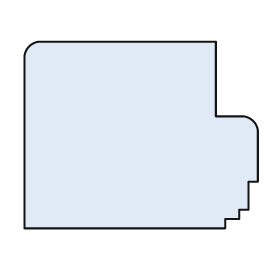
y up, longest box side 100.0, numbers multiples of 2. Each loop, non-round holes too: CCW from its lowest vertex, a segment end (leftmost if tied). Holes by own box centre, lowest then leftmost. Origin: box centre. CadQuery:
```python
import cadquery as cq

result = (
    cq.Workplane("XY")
    .moveTo(-50.0, -40.0)
    .lineTo(36.0, -40.0)
    .lineTo(36.0, -36.0)
    .lineTo(42.0, -36.0)
    .lineTo(42.0, -32.0)
    .lineTo(46.0, -32.0)
    .lineTo(46.0, -20.0)
    .lineTo(50.0, -20.0)
    .lineTo(50.0, 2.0)
    .threePointArc((48.0, 6.0), (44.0, 8.0))
    .lineTo(32.0, 8.0)
    .lineTo(32.0, 40.0)
    .lineTo(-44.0, 40.0)
    .threePointArc((-48.0, 38.0), (-50.0, 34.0))
    .close()
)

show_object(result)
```